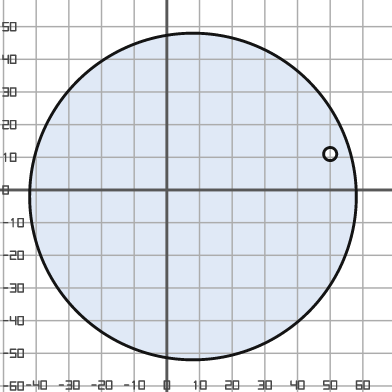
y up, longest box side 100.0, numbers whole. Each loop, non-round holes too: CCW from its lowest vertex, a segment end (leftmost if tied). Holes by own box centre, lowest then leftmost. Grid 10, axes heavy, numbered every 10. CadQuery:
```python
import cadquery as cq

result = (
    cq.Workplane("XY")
    .moveTo(8.0, -2.0)
    .circle(50.0)
    .moveTo(50.0, 11.0)
    .circle(2.0)
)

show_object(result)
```